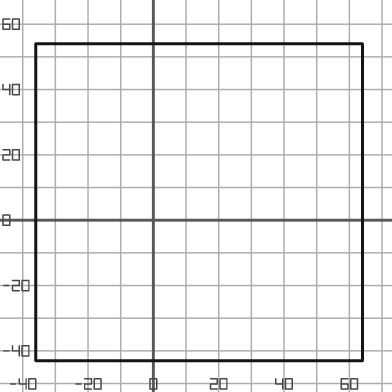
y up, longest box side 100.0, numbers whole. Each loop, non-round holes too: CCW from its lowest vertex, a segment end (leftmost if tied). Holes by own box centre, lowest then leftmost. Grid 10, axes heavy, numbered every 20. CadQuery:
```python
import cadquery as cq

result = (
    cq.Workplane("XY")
    .moveTo(-36.0, -43.0)
    .lineTo(64.0, -43.0)
    .lineTo(64.0, 54.0)
    .lineTo(-36.0, 54.0)
    .close()
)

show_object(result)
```